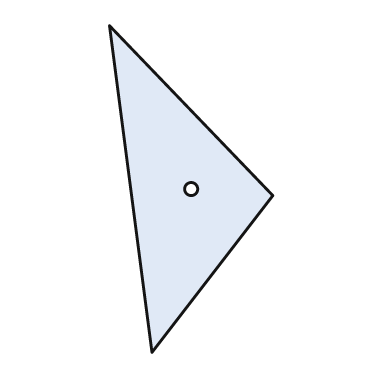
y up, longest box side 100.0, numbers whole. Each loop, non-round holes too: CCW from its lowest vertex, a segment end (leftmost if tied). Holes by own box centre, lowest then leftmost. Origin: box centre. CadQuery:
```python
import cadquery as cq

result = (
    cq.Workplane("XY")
    .moveTo(-12.0, -50.0)
    .lineTo(25.0, -2.0)
    .lineTo(-25.0, 50.0)
    .close()
    .moveTo(0.0, 0.0)
    .circle(2.0)
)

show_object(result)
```